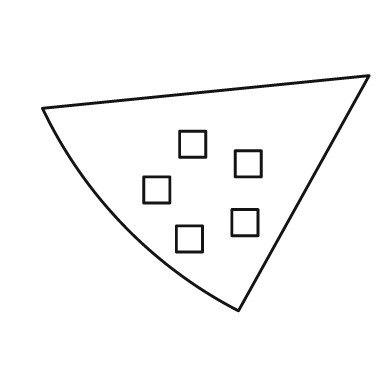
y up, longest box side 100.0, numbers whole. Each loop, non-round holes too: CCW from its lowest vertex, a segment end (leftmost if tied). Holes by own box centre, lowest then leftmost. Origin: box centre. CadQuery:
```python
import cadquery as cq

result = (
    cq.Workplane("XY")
    .moveTo(10.0, -36.0)
    .lineTo(50.0, 36.0)
    .lineTo(-50.0, 26.0)
    .threePointArc((-25.0, -10.0), (10.0, -36.0))
    .close()
    .moveTo(-9.0, -18.0)
    .lineTo(-1.0, -18.0)
    .lineTo(-1.0, -10.0)
    .lineTo(-9.0, -10.0)
    .close()
    .moveTo(8.0, -13.0)
    .lineTo(16.0, -13.0)
    .lineTo(16.0, -5.0)
    .lineTo(8.0, -5.0)
    .close()
    .moveTo(-19.0, -3.0)
    .lineTo(-11.0, -3.0)
    .lineTo(-11.0, 5.0)
    .lineTo(-19.0, 5.0)
    .close()
    .moveTo(9.0, 5.0)
    .lineTo(17.0, 5.0)
    .lineTo(17.0, 13.0)
    .lineTo(9.0, 13.0)
    .close()
    .moveTo(-8.0, 11.0)
    .lineTo(0.0, 11.0)
    .lineTo(0.0, 19.0)
    .lineTo(-8.0, 19.0)
    .close()
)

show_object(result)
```